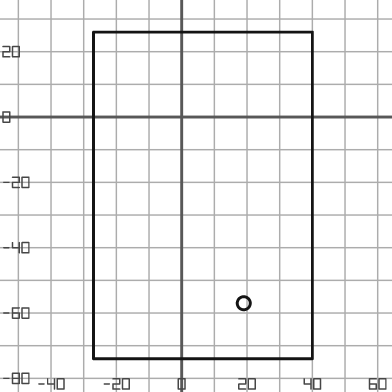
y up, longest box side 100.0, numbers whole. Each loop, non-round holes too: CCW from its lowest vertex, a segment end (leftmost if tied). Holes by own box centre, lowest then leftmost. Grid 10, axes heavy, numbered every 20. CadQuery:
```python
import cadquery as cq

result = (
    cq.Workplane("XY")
    .moveTo(-27.0, -74.0)
    .lineTo(40.0, -74.0)
    .lineTo(40.0, 26.0)
    .lineTo(-27.0, 26.0)
    .close()
    .moveTo(19.0, -57.0)
    .circle(2.0)
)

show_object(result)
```